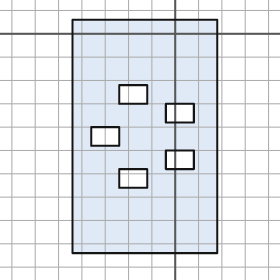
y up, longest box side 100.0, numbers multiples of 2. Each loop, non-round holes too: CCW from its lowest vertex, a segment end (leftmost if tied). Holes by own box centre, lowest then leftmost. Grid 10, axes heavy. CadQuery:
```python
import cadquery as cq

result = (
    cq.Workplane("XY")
    .moveTo(-44.0, -94.0)
    .lineTo(18.0, -94.0)
    .lineTo(18.0, 6.0)
    .lineTo(-44.0, 6.0)
    .close()
    .moveTo(-24.0, -66.0)
    .lineTo(-12.0, -66.0)
    .lineTo(-12.0, -58.0)
    .lineTo(-24.0, -58.0)
    .close()
    .moveTo(-4.0, -58.0)
    .lineTo(8.0, -58.0)
    .lineTo(8.0, -50.0)
    .lineTo(-4.0, -50.0)
    .close()
    .moveTo(-36.0, -48.0)
    .lineTo(-24.0, -48.0)
    .lineTo(-24.0, -40.0)
    .lineTo(-36.0, -40.0)
    .close()
    .moveTo(-4.0, -38.0)
    .lineTo(8.0, -38.0)
    .lineTo(8.0, -30.0)
    .lineTo(-4.0, -30.0)
    .close()
    .moveTo(-24.0, -30.0)
    .lineTo(-12.0, -30.0)
    .lineTo(-12.0, -22.0)
    .lineTo(-24.0, -22.0)
    .close()
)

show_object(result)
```